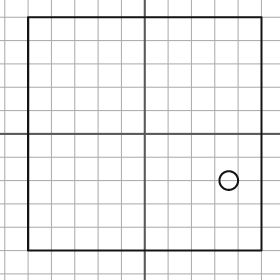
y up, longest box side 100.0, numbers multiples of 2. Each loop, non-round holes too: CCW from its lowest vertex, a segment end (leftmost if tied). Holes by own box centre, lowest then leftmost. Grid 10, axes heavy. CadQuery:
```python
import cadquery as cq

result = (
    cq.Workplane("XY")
    .moveTo(-50.0, -50.0)
    .lineTo(50.0, -50.0)
    .lineTo(50.0, 50.0)
    .lineTo(-50.0, 50.0)
    .close()
    .moveTo(36.0, -20.0)
    .circle(4.0)
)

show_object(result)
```